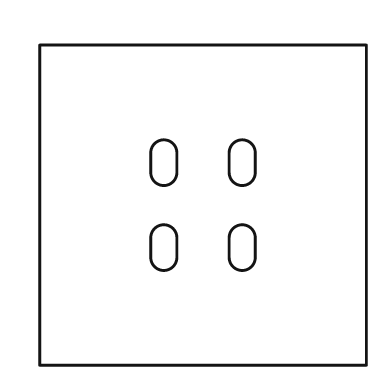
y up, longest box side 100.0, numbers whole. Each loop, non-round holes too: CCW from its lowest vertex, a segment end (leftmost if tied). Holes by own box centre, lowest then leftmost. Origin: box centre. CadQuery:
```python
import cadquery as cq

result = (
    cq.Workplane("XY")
    .moveTo(-50.0, -49.0)
    .lineTo(50.0, -49.0)
    .lineTo(50.0, 49.0)
    .lineTo(-50.0, 49.0)
    .close()
    .moveTo(-16.0, -16.0)
    .threePointArc((-12.0, -20.0), (-8.0, -16.0))
    .lineTo(-8.0, -10.0)
    .threePointArc((-12.0, -6.0), (-16.0, -10.0))
    .close()
    .moveTo(8.0, -16.0)
    .threePointArc((12.0, -20.0), (16.0, -16.0))
    .lineTo(16.0, -10.0)
    .threePointArc((12.0, -6.0), (8.0, -10.0))
    .close()
    .moveTo(-16.0, 10.0)
    .threePointArc((-12.0, 6.0), (-8.0, 10.0))
    .lineTo(-8.0, 16.0)
    .threePointArc((-12.0, 20.0), (-16.0, 16.0))
    .close()
    .moveTo(8.0, 10.0)
    .threePointArc((12.0, 6.0), (16.0, 10.0))
    .lineTo(16.0, 16.0)
    .threePointArc((12.0, 20.0), (8.0, 16.0))
    .close()
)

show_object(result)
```